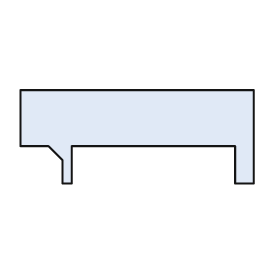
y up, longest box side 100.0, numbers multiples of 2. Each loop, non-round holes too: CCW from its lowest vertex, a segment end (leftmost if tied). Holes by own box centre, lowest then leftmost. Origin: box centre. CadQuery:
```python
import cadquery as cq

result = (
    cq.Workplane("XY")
    .moveTo(-32.0, -20.0)
    .lineTo(-28.0, -20.0)
    .lineTo(-28.0, -4.0)
    .lineTo(42.0, -4.0)
    .lineTo(42.0, -20.0)
    .lineTo(50.0, -20.0)
    .lineTo(50.0, 20.0)
    .lineTo(-50.0, 20.0)
    .lineTo(-50.0, -4.0)
    .lineTo(-38.0, -4.0)
    .lineTo(-32.0, -10.0)
    .close()
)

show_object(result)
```